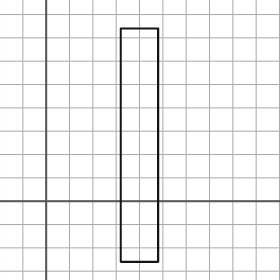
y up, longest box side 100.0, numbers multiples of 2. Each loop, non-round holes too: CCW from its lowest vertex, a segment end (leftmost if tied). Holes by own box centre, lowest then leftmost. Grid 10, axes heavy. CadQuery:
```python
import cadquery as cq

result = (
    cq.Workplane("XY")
    .moveTo(32.0, -26.0)
    .lineTo(48.0, -26.0)
    .lineTo(48.0, 74.0)
    .lineTo(32.0, 74.0)
    .close()
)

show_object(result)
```